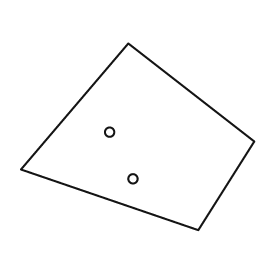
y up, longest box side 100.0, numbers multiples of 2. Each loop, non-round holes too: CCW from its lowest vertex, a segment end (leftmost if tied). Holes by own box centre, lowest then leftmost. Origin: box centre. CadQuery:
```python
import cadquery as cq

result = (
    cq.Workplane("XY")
    .moveTo(26.0, -40.0)
    .lineTo(50.0, -2.0)
    .lineTo(-4.0, 40.0)
    .lineTo(-50.0, -14.0)
    .close()
    .moveTo(-2.0, -18.0)
    .circle(2.0)
    .moveTo(-12.0, 2.0)
    .circle(2.0)
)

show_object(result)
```